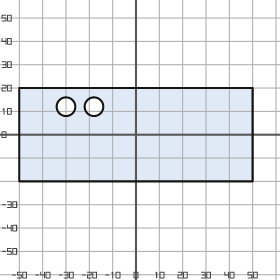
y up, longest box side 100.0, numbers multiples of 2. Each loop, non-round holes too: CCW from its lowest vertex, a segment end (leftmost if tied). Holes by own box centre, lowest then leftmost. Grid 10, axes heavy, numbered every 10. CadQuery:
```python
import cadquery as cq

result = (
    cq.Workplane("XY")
    .moveTo(-50.0, -20.0)
    .lineTo(50.0, -20.0)
    .lineTo(50.0, 20.0)
    .lineTo(-50.0, 20.0)
    .close()
    .moveTo(-30.0, 12.0)
    .circle(4.0)
    .moveTo(-18.0, 12.0)
    .circle(4.0)
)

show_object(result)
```